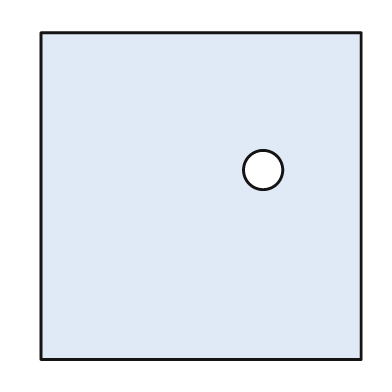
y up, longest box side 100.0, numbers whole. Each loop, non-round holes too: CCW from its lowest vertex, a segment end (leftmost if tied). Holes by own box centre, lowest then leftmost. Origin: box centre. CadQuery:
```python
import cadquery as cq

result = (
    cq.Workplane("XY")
    .moveTo(-49.0, -50.0)
    .lineTo(49.0, -50.0)
    .lineTo(49.0, 50.0)
    .lineTo(-49.0, 50.0)
    .close()
    .moveTo(19.0, 8.0)
    .circle(6.0)
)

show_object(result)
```